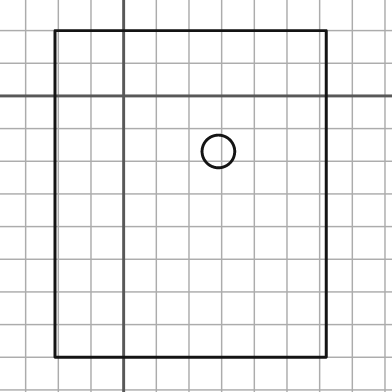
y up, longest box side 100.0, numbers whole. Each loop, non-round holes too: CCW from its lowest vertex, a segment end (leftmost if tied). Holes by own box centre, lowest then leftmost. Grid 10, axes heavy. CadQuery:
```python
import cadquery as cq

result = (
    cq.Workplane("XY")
    .moveTo(-21.0, -80.0)
    .lineTo(62.0, -80.0)
    .lineTo(62.0, 20.0)
    .lineTo(-21.0, 20.0)
    .close()
    .moveTo(29.0, -17.0)
    .circle(5.0)
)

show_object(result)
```